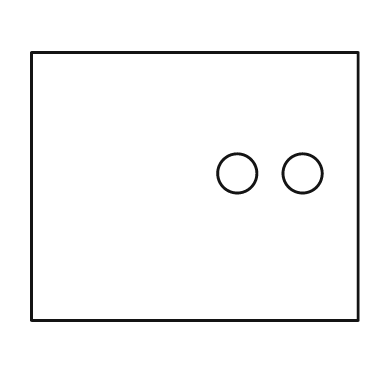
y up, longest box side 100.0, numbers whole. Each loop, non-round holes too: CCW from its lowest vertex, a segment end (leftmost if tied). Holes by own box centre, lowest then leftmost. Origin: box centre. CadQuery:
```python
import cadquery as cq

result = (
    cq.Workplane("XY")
    .moveTo(-50.0, -41.0)
    .lineTo(50.0, -41.0)
    .lineTo(50.0, 41.0)
    .lineTo(-50.0, 41.0)
    .close()
    .moveTo(13.0, 4.0)
    .circle(6.0)
    .moveTo(33.0, 4.0)
    .circle(6.0)
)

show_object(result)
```